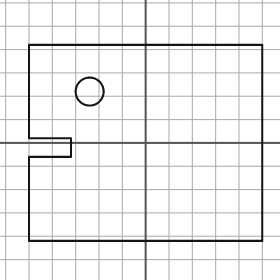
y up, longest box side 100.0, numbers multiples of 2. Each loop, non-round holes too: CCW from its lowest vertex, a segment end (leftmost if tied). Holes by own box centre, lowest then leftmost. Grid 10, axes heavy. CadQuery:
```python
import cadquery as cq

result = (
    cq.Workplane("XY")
    .moveTo(-50.0, -42.0)
    .lineTo(50.0, -42.0)
    .lineTo(50.0, 42.0)
    .lineTo(-50.0, 42.0)
    .lineTo(-50.0, 2.0)
    .lineTo(-32.0, 2.0)
    .lineTo(-32.0, -6.0)
    .lineTo(-50.0, -6.0)
    .close()
    .moveTo(-24.0, 22.0)
    .circle(6.0)
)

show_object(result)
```